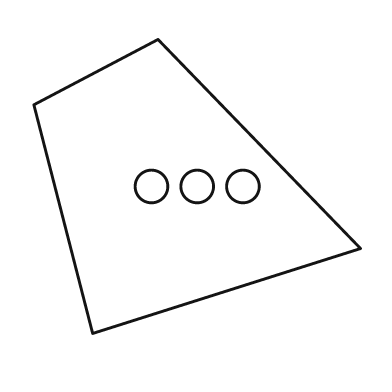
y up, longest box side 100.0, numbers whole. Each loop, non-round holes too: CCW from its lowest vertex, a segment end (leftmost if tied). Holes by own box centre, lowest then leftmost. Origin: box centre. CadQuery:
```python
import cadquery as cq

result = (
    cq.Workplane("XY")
    .moveTo(-32.0, -45.0)
    .lineTo(50.0, -19.0)
    .lineTo(-12.0, 45.0)
    .lineTo(-50.0, 25.0)
    .close()
    .moveTo(-14.0, 0.0)
    .circle(5.0)
    .moveTo(0.0, 0.0)
    .circle(5.0)
    .moveTo(14.0, 0.0)
    .circle(5.0)
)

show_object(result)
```